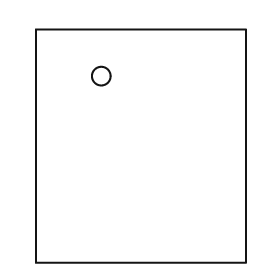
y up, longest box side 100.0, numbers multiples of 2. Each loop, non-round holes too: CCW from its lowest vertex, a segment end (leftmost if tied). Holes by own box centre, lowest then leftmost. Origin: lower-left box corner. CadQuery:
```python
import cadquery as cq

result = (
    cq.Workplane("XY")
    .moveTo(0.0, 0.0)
    .lineTo(90.0, 0.0)
    .lineTo(90.0, 100.0)
    .lineTo(0.0, 100.0)
    .close()
    .moveTo(28.0, 80.0)
    .circle(4.0)
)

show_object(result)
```